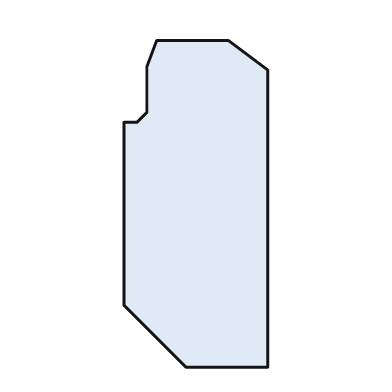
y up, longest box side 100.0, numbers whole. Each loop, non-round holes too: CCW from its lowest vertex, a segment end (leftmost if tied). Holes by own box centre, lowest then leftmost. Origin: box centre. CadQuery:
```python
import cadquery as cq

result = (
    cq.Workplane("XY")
    .moveTo(-3.0, -50.0)
    .lineTo(22.0, -50.0)
    .lineTo(22.0, 41.0)
    .lineTo(10.0, 50.0)
    .lineTo(-12.0, 50.0)
    .lineTo(-15.0, 42.0)
    .lineTo(-15.0, 28.0)
    .lineTo(-18.0, 25.0)
    .lineTo(-22.0, 25.0)
    .lineTo(-22.0, -31.0)
    .close()
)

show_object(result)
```